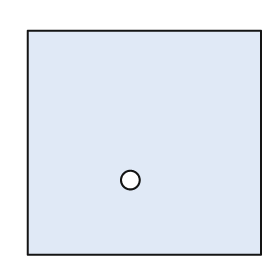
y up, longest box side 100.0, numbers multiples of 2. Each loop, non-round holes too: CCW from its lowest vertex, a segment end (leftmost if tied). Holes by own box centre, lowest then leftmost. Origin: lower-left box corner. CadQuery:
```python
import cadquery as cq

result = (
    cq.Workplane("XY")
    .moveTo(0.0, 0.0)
    .lineTo(100.0, 0.0)
    .lineTo(100.0, 96.0)
    .lineTo(0.0, 96.0)
    .close()
    .moveTo(44.0, 32.0)
    .circle(4.0)
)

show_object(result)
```